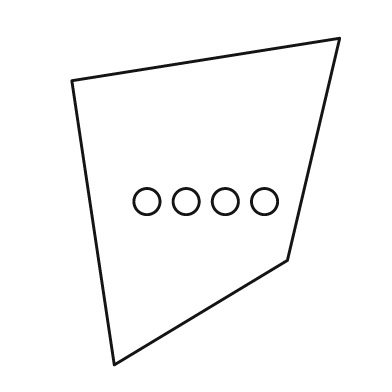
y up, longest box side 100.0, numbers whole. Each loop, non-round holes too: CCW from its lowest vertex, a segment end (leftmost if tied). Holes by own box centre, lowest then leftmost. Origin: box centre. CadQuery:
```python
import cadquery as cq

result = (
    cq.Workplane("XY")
    .moveTo(-28.0, -50.0)
    .lineTo(25.0, -18.0)
    .lineTo(41.0, 50.0)
    .lineTo(-41.0, 37.0)
    .close()
    .moveTo(-18.0, 0.0)
    .circle(4.0)
    .moveTo(-6.0, 0.0)
    .circle(4.0)
    .moveTo(6.0, 0.0)
    .circle(4.0)
    .moveTo(18.0, 0.0)
    .circle(4.0)
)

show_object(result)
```